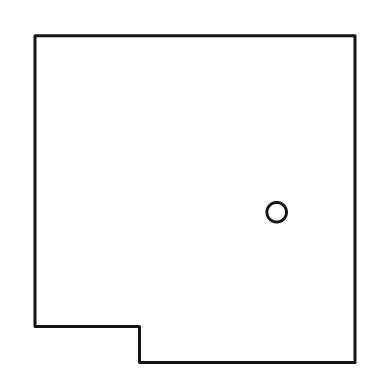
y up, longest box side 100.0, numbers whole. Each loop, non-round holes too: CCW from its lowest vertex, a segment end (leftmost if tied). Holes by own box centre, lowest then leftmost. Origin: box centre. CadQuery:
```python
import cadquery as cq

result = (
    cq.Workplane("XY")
    .moveTo(-17.0, -50.0)
    .lineTo(49.0, -50.0)
    .lineTo(49.0, 50.0)
    .lineTo(-49.0, 50.0)
    .lineTo(-49.0, -39.0)
    .lineTo(-17.0, -39.0)
    .close()
    .moveTo(25.0, -4.0)
    .circle(3.0)
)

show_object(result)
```